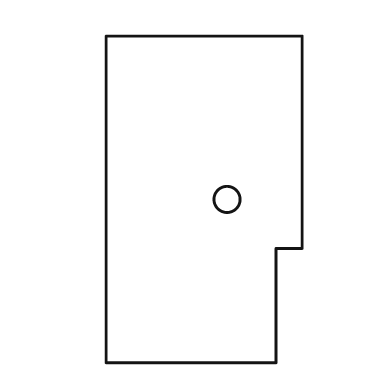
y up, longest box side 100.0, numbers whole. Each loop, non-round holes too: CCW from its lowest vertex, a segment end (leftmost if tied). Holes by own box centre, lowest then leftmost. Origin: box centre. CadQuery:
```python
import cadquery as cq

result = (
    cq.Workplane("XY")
    .moveTo(-30.0, -50.0)
    .lineTo(22.0, -50.0)
    .lineTo(22.0, -15.0)
    .lineTo(30.0, -15.0)
    .lineTo(30.0, 50.0)
    .lineTo(-30.0, 50.0)
    .close()
    .moveTo(7.0, 0.0)
    .circle(4.0)
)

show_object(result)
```